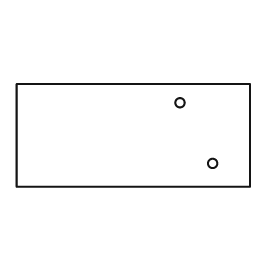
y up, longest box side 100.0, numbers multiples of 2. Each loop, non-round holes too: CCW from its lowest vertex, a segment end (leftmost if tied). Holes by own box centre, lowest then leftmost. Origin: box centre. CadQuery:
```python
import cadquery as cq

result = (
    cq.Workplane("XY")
    .moveTo(-50.0, -22.0)
    .lineTo(50.0, -22.0)
    .lineTo(50.0, 22.0)
    .lineTo(-50.0, 22.0)
    .close()
    .moveTo(34.0, -12.0)
    .circle(2.0)
    .moveTo(20.0, 14.0)
    .circle(2.0)
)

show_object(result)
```